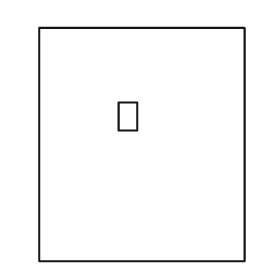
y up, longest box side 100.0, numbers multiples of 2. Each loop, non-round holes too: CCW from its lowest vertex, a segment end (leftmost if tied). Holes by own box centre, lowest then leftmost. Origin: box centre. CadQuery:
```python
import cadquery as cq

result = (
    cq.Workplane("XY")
    .moveTo(-44.0, -50.0)
    .lineTo(44.0, -50.0)
    .lineTo(44.0, 50.0)
    .lineTo(-44.0, 50.0)
    .close()
    .moveTo(-10.0, 6.0)
    .lineTo(-2.0, 6.0)
    .lineTo(-2.0, 18.0)
    .lineTo(-10.0, 18.0)
    .close()
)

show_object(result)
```